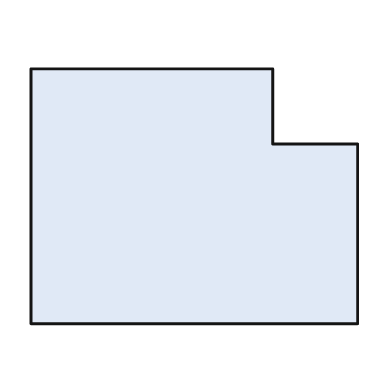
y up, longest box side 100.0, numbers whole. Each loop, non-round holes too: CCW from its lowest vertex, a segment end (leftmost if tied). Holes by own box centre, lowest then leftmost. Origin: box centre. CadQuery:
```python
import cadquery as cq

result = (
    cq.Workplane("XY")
    .moveTo(-50.0, -39.0)
    .lineTo(50.0, -39.0)
    .lineTo(50.0, 16.0)
    .lineTo(24.0, 16.0)
    .lineTo(24.0, 39.0)
    .lineTo(-50.0, 39.0)
    .close()
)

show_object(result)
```